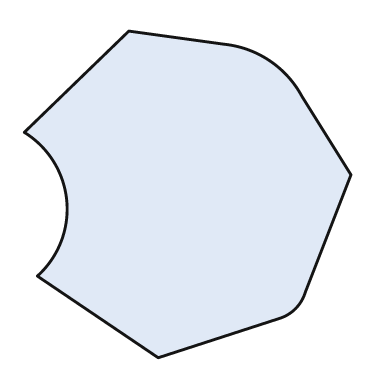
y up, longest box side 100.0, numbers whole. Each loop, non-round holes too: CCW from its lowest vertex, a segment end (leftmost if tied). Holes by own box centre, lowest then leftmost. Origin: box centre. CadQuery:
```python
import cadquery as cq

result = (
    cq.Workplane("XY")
    .moveTo(-9.0, -50.0)
    .lineTo(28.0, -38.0)
    .threePointArc((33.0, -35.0), (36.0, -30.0))
    .lineTo(50.0, 6.0)
    .lineTo(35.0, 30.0)
    .threePointArc((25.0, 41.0), (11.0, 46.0))
    .lineTo(-18.0, 50.0)
    .lineTo(-50.0, 19.0)
    .threePointArc((-37.0, -2.0), (-46.0, -25.0))
    .close()
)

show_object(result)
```